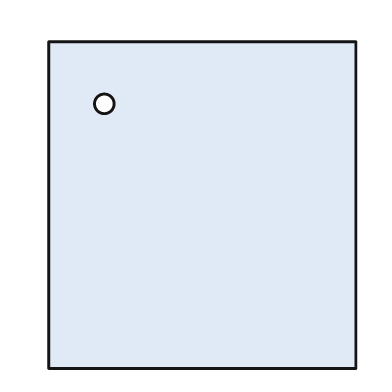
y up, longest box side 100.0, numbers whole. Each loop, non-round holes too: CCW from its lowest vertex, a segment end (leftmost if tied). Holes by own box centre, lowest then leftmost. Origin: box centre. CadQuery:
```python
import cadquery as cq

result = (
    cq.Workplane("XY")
    .moveTo(-47.0, -50.0)
    .lineTo(47.0, -50.0)
    .lineTo(47.0, 50.0)
    .lineTo(-47.0, 50.0)
    .close()
    .moveTo(-30.0, 31.0)
    .circle(3.0)
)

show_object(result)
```